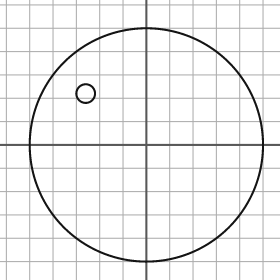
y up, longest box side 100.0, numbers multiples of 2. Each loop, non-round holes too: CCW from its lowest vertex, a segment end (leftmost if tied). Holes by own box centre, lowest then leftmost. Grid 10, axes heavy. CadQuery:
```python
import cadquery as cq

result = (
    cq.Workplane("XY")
    .moveTo(0.0, 0.0)
    .circle(50.0)
    .moveTo(-26.0, 22.0)
    .circle(4.0)
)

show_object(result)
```